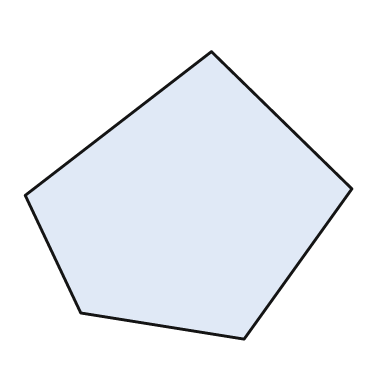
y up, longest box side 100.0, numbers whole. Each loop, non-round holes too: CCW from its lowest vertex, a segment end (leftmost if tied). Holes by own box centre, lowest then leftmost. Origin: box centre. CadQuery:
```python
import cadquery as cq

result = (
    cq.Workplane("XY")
    .moveTo(17.0, -44.0)
    .lineTo(50.0, 2.0)
    .lineTo(7.0, 44.0)
    .lineTo(-50.0, 0.0)
    .lineTo(-33.0, -36.0)
    .close()
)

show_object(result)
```